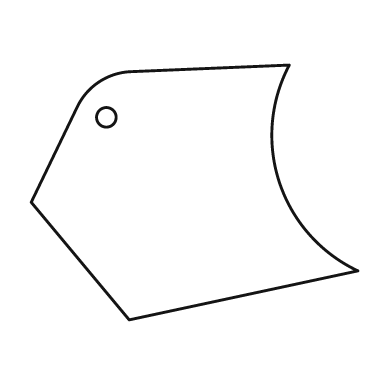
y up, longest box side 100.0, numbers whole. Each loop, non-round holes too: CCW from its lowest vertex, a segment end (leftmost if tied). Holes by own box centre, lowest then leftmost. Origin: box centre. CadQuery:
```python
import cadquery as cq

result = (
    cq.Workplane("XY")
    .moveTo(-20.0, -39.0)
    .lineTo(50.0, -24.0)
    .threePointArc((26.0, 3.0), (29.0, 39.0))
    .lineTo(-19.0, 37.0)
    .threePointArc((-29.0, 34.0), (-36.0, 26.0))
    .lineTo(-50.0, -3.0)
    .close()
    .moveTo(-27.0, 23.0)
    .circle(3.0)
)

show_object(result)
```